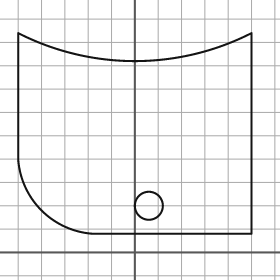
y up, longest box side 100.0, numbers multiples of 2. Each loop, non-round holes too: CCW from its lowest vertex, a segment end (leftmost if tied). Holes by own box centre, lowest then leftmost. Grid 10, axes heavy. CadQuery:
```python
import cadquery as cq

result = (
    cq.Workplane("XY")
    .moveTo(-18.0, 8.0)
    .lineTo(50.0, 8.0)
    .lineTo(50.0, 94.0)
    .threePointArc((0.0, 82.0), (-50.0, 94.0))
    .lineTo(-50.0, 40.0)
    .threePointArc((-40.0, 18.0), (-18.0, 8.0))
    .close()
    .moveTo(6.0, 20.0)
    .circle(6.0)
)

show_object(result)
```